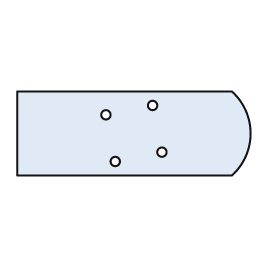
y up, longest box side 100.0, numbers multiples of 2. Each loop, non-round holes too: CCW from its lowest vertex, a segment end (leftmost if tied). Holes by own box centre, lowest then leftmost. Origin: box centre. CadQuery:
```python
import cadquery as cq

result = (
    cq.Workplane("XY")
    .moveTo(-50.0, -18.0)
    .lineTo(42.0, -18.0)
    .threePointArc((50.0, 0.0), (42.0, 18.0))
    .lineTo(-50.0, 18.0)
    .close()
    .moveTo(-8.0, -12.0)
    .circle(2.0)
    .moveTo(12.0, -8.0)
    .circle(2.0)
    .moveTo(-12.0, 8.0)
    .circle(2.0)
    .moveTo(8.0, 12.0)
    .circle(2.0)
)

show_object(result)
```